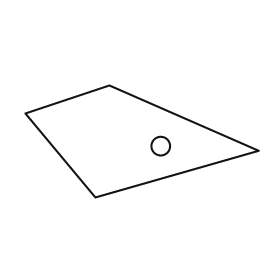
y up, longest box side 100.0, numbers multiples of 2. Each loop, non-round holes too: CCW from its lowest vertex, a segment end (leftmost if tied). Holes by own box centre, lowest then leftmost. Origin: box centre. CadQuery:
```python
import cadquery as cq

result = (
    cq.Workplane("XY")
    .moveTo(-20.0, -24.0)
    .lineTo(50.0, -4.0)
    .lineTo(-14.0, 24.0)
    .lineTo(-50.0, 12.0)
    .close()
    .moveTo(8.0, -2.0)
    .circle(4.0)
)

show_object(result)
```